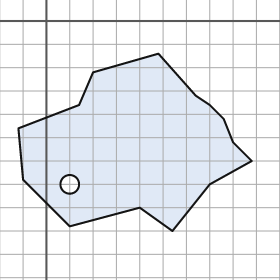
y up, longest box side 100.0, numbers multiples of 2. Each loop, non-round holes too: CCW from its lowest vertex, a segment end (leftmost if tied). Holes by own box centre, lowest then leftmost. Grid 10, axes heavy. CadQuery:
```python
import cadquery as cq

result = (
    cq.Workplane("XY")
    .moveTo(54.0, -90.0)
    .lineTo(70.0, -70.0)
    .lineTo(88.0, -60.0)
    .lineTo(80.0, -52.0)
    .lineTo(76.0, -42.0)
    .lineTo(70.0, -36.0)
    .lineTo(64.0, -32.0)
    .lineTo(48.0, -14.0)
    .lineTo(20.0, -22.0)
    .lineTo(14.0, -36.0)
    .lineTo(-12.0, -46.0)
    .lineTo(-10.0, -68.0)
    .lineTo(10.0, -88.0)
    .lineTo(40.0, -80.0)
    .close()
    .moveTo(10.0, -70.0)
    .circle(4.0)
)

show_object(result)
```